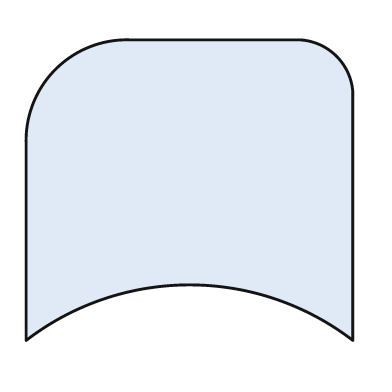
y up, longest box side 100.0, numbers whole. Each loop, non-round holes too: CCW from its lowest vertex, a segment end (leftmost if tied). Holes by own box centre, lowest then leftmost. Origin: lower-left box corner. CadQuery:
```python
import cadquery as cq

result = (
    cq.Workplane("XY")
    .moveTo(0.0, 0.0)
    .threePointArc((50.0, 17.0), (100.0, 0.0))
    .lineTo(100.0, 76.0)
    .threePointArc((95.0, 87.0), (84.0, 92.0))
    .lineTo(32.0, 92.0)
    .threePointArc((9.0, 83.0), (0.0, 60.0))
    .close()
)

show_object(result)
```